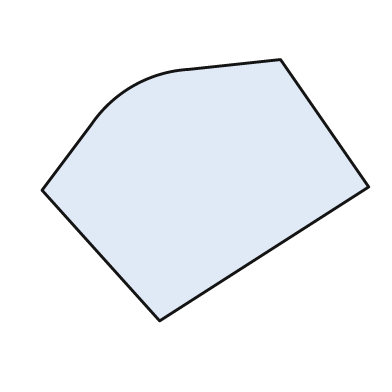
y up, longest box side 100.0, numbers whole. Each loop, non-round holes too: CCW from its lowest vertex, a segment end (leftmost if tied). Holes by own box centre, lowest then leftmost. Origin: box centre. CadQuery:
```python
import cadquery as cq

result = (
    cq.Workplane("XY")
    .moveTo(-14.0, -40.0)
    .lineTo(50.0, 1.0)
    .lineTo(23.0, 40.0)
    .lineTo(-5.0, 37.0)
    .threePointArc((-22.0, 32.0), (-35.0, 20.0))
    .lineTo(-50.0, 0.0)
    .close()
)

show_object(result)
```